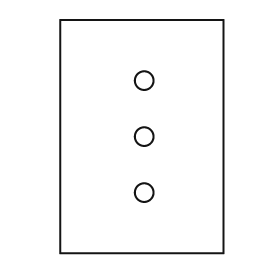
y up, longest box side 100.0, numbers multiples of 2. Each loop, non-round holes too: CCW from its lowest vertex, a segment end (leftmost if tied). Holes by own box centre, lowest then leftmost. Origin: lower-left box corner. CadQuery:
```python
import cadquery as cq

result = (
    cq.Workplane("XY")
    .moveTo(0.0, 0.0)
    .lineTo(70.0, 0.0)
    .lineTo(70.0, 100.0)
    .lineTo(0.0, 100.0)
    .close()
    .moveTo(36.0, 26.0)
    .circle(4.0)
    .moveTo(36.0, 50.0)
    .circle(4.0)
    .moveTo(36.0, 74.0)
    .circle(4.0)
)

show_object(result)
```